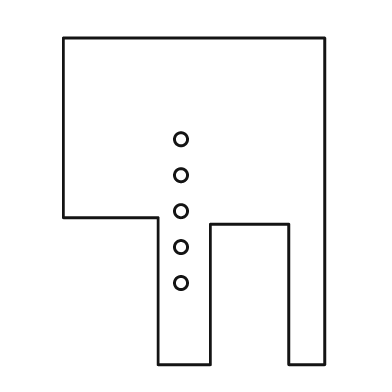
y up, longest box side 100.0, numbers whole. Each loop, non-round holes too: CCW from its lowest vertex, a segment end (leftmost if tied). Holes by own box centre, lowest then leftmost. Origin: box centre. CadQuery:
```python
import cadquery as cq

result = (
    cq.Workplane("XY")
    .moveTo(-11.0, -50.0)
    .lineTo(5.0, -50.0)
    .lineTo(5.0, -7.0)
    .lineTo(29.0, -7.0)
    .lineTo(29.0, -50.0)
    .lineTo(40.0, -50.0)
    .lineTo(40.0, 50.0)
    .lineTo(-40.0, 50.0)
    .lineTo(-40.0, -5.0)
    .lineTo(-11.0, -5.0)
    .close()
    .moveTo(-4.0, -25.0)
    .circle(2.0)
    .moveTo(-4.0, -14.0)
    .circle(2.0)
    .moveTo(-4.0, -3.0)
    .circle(2.0)
    .moveTo(-4.0, 8.0)
    .circle(2.0)
    .moveTo(-4.0, 19.0)
    .circle(2.0)
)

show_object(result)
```